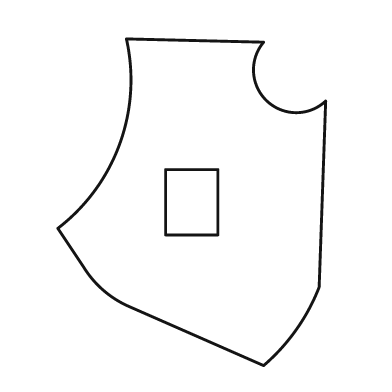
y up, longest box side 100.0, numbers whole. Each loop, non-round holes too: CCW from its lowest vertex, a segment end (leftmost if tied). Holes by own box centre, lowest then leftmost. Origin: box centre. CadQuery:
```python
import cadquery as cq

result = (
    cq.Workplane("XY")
    .moveTo(22.0, -50.0)
    .threePointArc((32.0, -39.0), (39.0, -26.0))
    .lineTo(41.0, 31.0)
    .threePointArc((23.0, 31.0), (22.0, 49.0))
    .lineTo(-20.0, 50.0)
    .threePointArc((-22.0, 18.0), (-41.0, -8.0))
    .lineTo(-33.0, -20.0)
    .threePointArc((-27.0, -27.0), (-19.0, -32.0))
    .close()
    .moveTo(-8.0, -10.0)
    .lineTo(8.0, -10.0)
    .lineTo(8.0, 10.0)
    .lineTo(-8.0, 10.0)
    .close()
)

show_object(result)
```